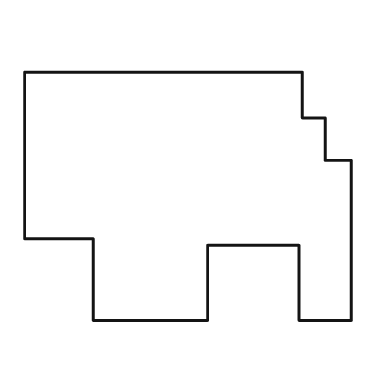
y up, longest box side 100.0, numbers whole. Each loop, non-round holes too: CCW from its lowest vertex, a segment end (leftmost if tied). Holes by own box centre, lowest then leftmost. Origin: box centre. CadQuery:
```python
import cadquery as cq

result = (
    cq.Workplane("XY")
    .moveTo(-29.0, -38.0)
    .lineTo(6.0, -38.0)
    .lineTo(6.0, -15.0)
    .lineTo(34.0, -15.0)
    .lineTo(34.0, -38.0)
    .lineTo(50.0, -38.0)
    .lineTo(50.0, 11.0)
    .lineTo(42.0, 11.0)
    .lineTo(42.0, 24.0)
    .lineTo(35.0, 24.0)
    .lineTo(35.0, 38.0)
    .lineTo(-50.0, 38.0)
    .lineTo(-50.0, -13.0)
    .lineTo(-29.0, -13.0)
    .close()
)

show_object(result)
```